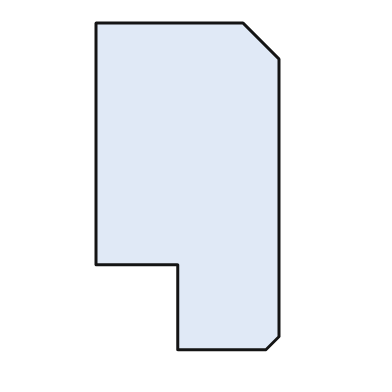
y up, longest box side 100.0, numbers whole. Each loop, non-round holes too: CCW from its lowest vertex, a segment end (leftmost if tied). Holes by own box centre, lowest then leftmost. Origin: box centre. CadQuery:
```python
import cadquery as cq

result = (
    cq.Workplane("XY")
    .moveTo(-3.0, -50.0)
    .lineTo(24.0, -50.0)
    .lineTo(28.0, -46.0)
    .lineTo(28.0, 39.0)
    .lineTo(17.0, 50.0)
    .lineTo(-28.0, 50.0)
    .lineTo(-28.0, -24.0)
    .lineTo(-3.0, -24.0)
    .close()
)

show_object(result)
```